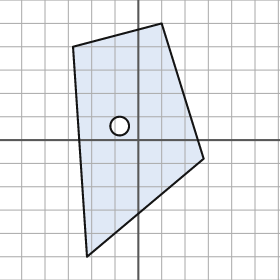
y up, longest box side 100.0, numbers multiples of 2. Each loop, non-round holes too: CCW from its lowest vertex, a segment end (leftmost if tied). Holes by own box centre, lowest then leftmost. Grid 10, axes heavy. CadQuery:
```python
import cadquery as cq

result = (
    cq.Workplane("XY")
    .moveTo(-22.0, -50.0)
    .lineTo(28.0, -8.0)
    .lineTo(10.0, 50.0)
    .lineTo(-28.0, 40.0)
    .close()
    .moveTo(-8.0, 6.0)
    .circle(4.0)
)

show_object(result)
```